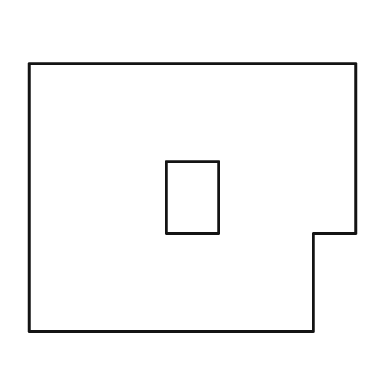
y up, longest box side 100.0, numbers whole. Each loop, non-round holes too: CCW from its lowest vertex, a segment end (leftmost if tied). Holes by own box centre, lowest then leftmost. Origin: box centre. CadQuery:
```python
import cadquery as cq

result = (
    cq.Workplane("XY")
    .moveTo(-50.0, -41.0)
    .lineTo(37.0, -41.0)
    .lineTo(37.0, -11.0)
    .lineTo(50.0, -11.0)
    .lineTo(50.0, 41.0)
    .lineTo(-50.0, 41.0)
    .close()
    .moveTo(-8.0, -11.0)
    .lineTo(8.0, -11.0)
    .lineTo(8.0, 11.0)
    .lineTo(-8.0, 11.0)
    .close()
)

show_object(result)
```